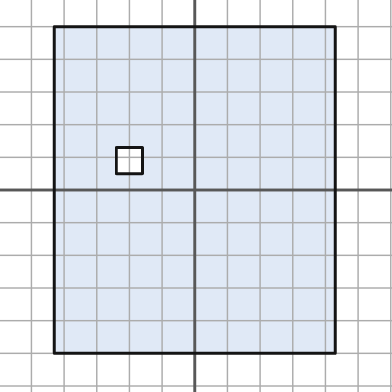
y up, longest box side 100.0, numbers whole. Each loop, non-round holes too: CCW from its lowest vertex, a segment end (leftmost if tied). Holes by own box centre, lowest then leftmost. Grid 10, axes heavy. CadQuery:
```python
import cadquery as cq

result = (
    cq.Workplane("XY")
    .moveTo(-43.0, -50.0)
    .lineTo(43.0, -50.0)
    .lineTo(43.0, 50.0)
    .lineTo(-43.0, 50.0)
    .close()
    .moveTo(-24.0, 5.0)
    .lineTo(-16.0, 5.0)
    .lineTo(-16.0, 13.0)
    .lineTo(-24.0, 13.0)
    .close()
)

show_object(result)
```